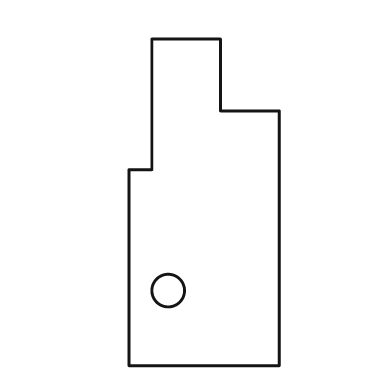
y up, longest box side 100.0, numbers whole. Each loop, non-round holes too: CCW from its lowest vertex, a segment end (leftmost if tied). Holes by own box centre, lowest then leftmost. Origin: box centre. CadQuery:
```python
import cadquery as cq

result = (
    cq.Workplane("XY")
    .moveTo(-23.0, -50.0)
    .lineTo(23.0, -50.0)
    .lineTo(23.0, 28.0)
    .lineTo(5.0, 28.0)
    .lineTo(5.0, 50.0)
    .lineTo(-16.0, 50.0)
    .lineTo(-16.0, 10.0)
    .lineTo(-23.0, 10.0)
    .close()
    .moveTo(-11.0, -27.0)
    .circle(5.0)
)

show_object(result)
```